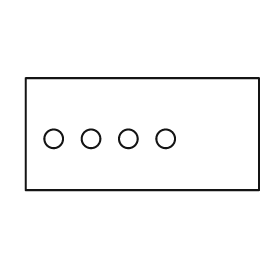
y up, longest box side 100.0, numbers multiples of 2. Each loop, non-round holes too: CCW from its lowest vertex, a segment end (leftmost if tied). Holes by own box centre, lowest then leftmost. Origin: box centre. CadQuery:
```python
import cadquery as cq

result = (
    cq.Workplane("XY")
    .moveTo(-50.0, -24.0)
    .lineTo(50.0, -24.0)
    .lineTo(50.0, 24.0)
    .lineTo(-50.0, 24.0)
    .close()
    .moveTo(-38.0, -2.0)
    .circle(4.0)
    .moveTo(-22.0, -2.0)
    .circle(4.0)
    .moveTo(-6.0, -2.0)
    .circle(4.0)
    .moveTo(10.0, -2.0)
    .circle(4.0)
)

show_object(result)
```